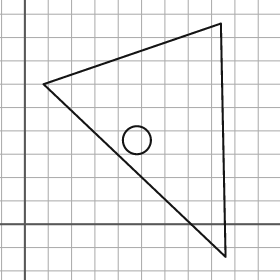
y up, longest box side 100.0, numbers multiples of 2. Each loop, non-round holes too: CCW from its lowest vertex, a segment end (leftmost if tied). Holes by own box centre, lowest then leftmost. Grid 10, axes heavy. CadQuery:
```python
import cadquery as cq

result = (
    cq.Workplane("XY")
    .moveTo(86.0, -14.0)
    .lineTo(84.0, 86.0)
    .lineTo(8.0, 60.0)
    .close()
    .moveTo(48.0, 36.0)
    .circle(6.0)
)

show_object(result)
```